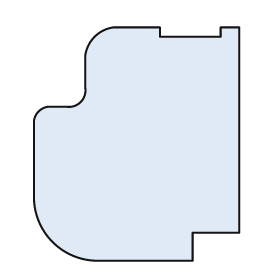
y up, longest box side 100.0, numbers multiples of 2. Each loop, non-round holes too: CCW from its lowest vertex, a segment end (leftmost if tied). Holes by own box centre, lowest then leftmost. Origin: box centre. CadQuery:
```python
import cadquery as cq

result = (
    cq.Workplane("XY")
    .moveTo(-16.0, -50.0)
    .lineTo(24.0, -50.0)
    .lineTo(24.0, -38.0)
    .lineTo(44.0, -38.0)
    .lineTo(44.0, 50.0)
    .lineTo(36.0, 50.0)
    .lineTo(36.0, 46.0)
    .lineTo(10.0, 46.0)
    .lineTo(10.0, 50.0)
    .lineTo(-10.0, 50.0)
    .threePointArc((-18.0, 46.0), (-22.0, 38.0))
    .lineTo(-22.0, 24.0)
    .threePointArc((-24.0, 18.0), (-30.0, 16.0))
    .lineTo(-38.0, 16.0)
    .threePointArc((-42.0, 14.0), (-44.0, 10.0))
    .lineTo(-44.0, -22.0)
    .threePointArc((-36.0, -42.0), (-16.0, -50.0))
    .close()
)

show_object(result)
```